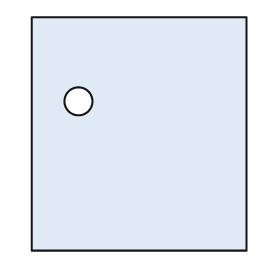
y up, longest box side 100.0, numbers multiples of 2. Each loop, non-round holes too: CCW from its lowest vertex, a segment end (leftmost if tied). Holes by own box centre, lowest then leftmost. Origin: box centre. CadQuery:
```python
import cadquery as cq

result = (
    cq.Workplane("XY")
    .moveTo(-46.0, -50.0)
    .lineTo(46.0, -50.0)
    .lineTo(46.0, 50.0)
    .lineTo(-46.0, 50.0)
    .close()
    .moveTo(-26.0, 14.0)
    .circle(6.0)
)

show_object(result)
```